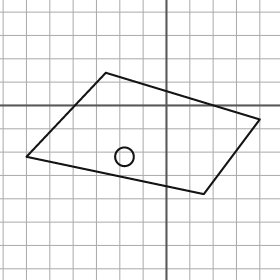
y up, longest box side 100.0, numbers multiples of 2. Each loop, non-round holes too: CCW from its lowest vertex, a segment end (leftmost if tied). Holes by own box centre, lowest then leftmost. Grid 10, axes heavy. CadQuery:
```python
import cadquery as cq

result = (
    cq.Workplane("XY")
    .moveTo(16.0, -38.0)
    .lineTo(40.0, -6.0)
    .lineTo(-26.0, 14.0)
    .lineTo(-60.0, -22.0)
    .close()
    .moveTo(-18.0, -22.0)
    .circle(4.0)
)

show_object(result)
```